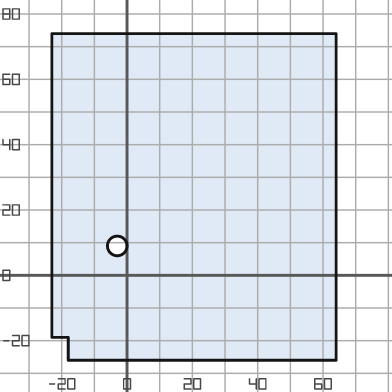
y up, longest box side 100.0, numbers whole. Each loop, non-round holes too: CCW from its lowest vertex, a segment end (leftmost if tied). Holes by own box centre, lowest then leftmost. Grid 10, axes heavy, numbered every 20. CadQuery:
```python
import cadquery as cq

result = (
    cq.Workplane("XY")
    .moveTo(-18.0, -26.0)
    .lineTo(64.0, -26.0)
    .lineTo(64.0, 74.0)
    .lineTo(-23.0, 74.0)
    .lineTo(-23.0, -19.0)
    .lineTo(-18.0, -19.0)
    .close()
    .moveTo(-3.0, 9.0)
    .circle(3.0)
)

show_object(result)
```